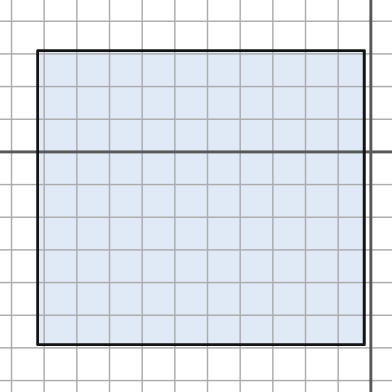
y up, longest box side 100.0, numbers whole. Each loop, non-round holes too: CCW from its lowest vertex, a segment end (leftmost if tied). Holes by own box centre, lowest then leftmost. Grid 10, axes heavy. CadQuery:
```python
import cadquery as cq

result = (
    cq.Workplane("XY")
    .moveTo(-102.0, -59.0)
    .lineTo(-2.0, -59.0)
    .lineTo(-2.0, 31.0)
    .lineTo(-102.0, 31.0)
    .close()
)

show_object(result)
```